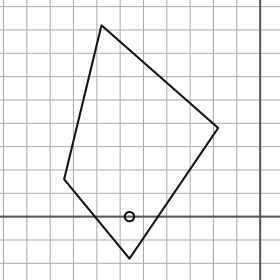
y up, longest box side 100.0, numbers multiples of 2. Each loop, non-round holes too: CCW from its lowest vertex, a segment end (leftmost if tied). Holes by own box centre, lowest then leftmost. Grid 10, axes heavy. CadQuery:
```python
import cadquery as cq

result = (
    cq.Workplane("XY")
    .moveTo(-56.0, -18.0)
    .lineTo(-18.0, 38.0)
    .lineTo(-68.0, 82.0)
    .lineTo(-84.0, 16.0)
    .close()
    .moveTo(-56.0, 0.0)
    .circle(2.0)
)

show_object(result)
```